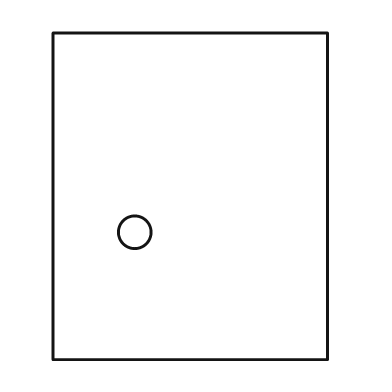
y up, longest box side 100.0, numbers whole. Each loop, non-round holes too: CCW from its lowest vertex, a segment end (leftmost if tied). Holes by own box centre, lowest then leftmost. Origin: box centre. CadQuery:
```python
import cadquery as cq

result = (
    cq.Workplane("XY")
    .moveTo(-42.0, -50.0)
    .lineTo(42.0, -50.0)
    .lineTo(42.0, 50.0)
    .lineTo(-42.0, 50.0)
    .close()
    .moveTo(-17.0, -11.0)
    .circle(5.0)
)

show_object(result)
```